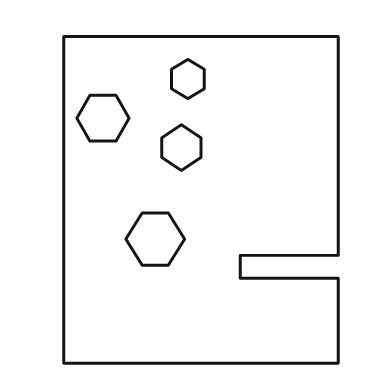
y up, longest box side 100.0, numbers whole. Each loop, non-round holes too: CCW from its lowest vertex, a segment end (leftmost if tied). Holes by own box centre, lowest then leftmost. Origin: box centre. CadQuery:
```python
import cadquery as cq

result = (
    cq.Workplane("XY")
    .moveTo(-42.0, -50.0)
    .lineTo(42.0, -50.0)
    .lineTo(42.0, -24.0)
    .lineTo(12.0, -24.0)
    .lineTo(12.0, -17.0)
    .lineTo(42.0, -17.0)
    .lineTo(42.0, 50.0)
    .lineTo(-42.0, 50.0)
    .close()
    .moveTo(-18.0, -20.0)
    .lineTo(-10.0, -20.0)
    .lineTo(-5.0, -12.0)
    .lineTo(-10.0, -4.0)
    .lineTo(-18.0, -4.0)
    .lineTo(-23.0, -12.0)
    .close()
    .moveTo(-6.0, 9.0)
    .lineTo(0.0, 13.0)
    .lineTo(0.0, 19.0)
    .lineTo(-6.0, 23.0)
    .lineTo(-12.0, 19.0)
    .lineTo(-12.0, 13.0)
    .close()
    .moveTo(-34.0, 18.0)
    .lineTo(-26.0, 18.0)
    .lineTo(-22.0, 25.0)
    .lineTo(-26.0, 32.0)
    .lineTo(-34.0, 32.0)
    .lineTo(-38.0, 25.0)
    .close()
    .moveTo(-4.0, 31.0)
    .lineTo(1.0, 34.0)
    .lineTo(1.0, 40.0)
    .lineTo(-4.0, 43.0)
    .lineTo(-9.0, 40.0)
    .lineTo(-9.0, 34.0)
    .close()
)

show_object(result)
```